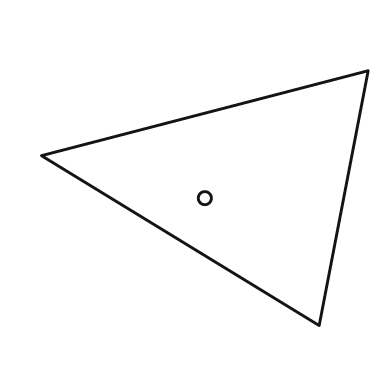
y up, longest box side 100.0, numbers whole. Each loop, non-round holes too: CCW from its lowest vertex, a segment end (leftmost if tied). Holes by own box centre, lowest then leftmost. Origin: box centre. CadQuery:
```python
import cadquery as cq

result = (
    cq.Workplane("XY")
    .moveTo(35.0, -39.0)
    .lineTo(50.0, 39.0)
    .lineTo(-50.0, 13.0)
    .close()
    .moveTo(0.0, 0.0)
    .circle(2.0)
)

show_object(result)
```